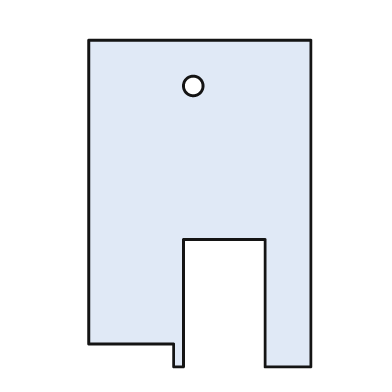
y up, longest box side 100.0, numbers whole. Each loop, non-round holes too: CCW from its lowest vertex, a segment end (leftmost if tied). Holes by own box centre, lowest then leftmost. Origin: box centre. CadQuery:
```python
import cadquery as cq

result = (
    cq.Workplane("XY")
    .moveTo(-8.0, -50.0)
    .lineTo(-5.0, -50.0)
    .lineTo(-5.0, -11.0)
    .lineTo(20.0, -11.0)
    .lineTo(20.0, -50.0)
    .lineTo(34.0, -50.0)
    .lineTo(34.0, 50.0)
    .lineTo(-34.0, 50.0)
    .lineTo(-34.0, -43.0)
    .lineTo(-8.0, -43.0)
    .close()
    .moveTo(-2.0, 36.0)
    .circle(3.0)
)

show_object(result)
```